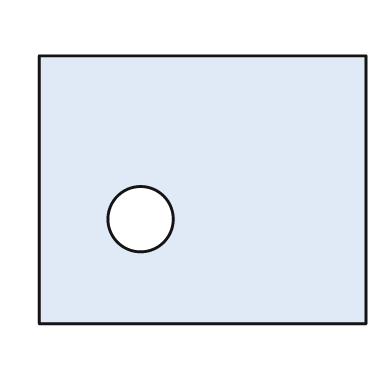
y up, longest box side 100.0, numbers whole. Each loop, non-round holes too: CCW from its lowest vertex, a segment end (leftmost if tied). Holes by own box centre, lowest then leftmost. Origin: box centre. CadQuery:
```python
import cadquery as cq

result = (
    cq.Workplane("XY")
    .moveTo(-50.0, -41.0)
    .lineTo(50.0, -41.0)
    .lineTo(50.0, 41.0)
    .lineTo(-50.0, 41.0)
    .close()
    .moveTo(-19.0, -9.0)
    .circle(10.0)
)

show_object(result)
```